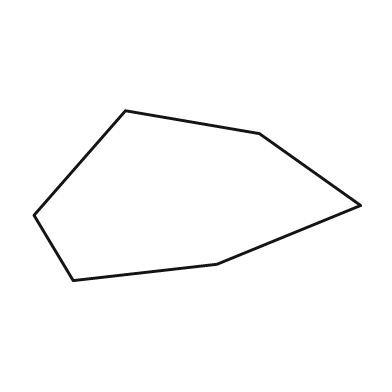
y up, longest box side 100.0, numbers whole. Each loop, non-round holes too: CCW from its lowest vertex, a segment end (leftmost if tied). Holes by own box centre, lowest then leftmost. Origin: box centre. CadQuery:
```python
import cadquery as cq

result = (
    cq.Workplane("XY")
    .moveTo(-38.0, -26.0)
    .lineTo(6.0, -21.0)
    .lineTo(50.0, -3.0)
    .lineTo(19.0, 19.0)
    .lineTo(-22.0, 26.0)
    .lineTo(-50.0, -6.0)
    .close()
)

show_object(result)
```